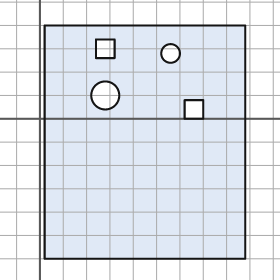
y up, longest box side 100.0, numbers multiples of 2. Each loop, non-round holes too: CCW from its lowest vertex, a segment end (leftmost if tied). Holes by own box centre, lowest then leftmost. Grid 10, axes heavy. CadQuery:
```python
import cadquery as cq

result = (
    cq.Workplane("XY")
    .moveTo(2.0, -60.0)
    .lineTo(88.0, -60.0)
    .lineTo(88.0, 40.0)
    .lineTo(2.0, 40.0)
    .close()
    .moveTo(62.0, 0.0)
    .lineTo(70.0, 0.0)
    .lineTo(70.0, 8.0)
    .lineTo(62.0, 8.0)
    .close()
    .moveTo(28.0, 10.0)
    .circle(6.0)
    .moveTo(56.0, 28.0)
    .circle(4.0)
    .moveTo(24.0, 26.0)
    .lineTo(32.0, 26.0)
    .lineTo(32.0, 34.0)
    .lineTo(24.0, 34.0)
    .close()
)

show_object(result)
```